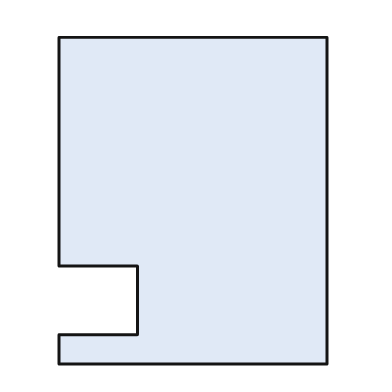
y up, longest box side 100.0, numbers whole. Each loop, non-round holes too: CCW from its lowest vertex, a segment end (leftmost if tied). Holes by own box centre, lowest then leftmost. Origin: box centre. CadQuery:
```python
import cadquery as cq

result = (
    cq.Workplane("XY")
    .moveTo(-41.0, -50.0)
    .lineTo(41.0, -50.0)
    .lineTo(41.0, 50.0)
    .lineTo(-41.0, 50.0)
    .lineTo(-41.0, -20.0)
    .lineTo(-17.0, -20.0)
    .lineTo(-17.0, -41.0)
    .lineTo(-41.0, -41.0)
    .close()
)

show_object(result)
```